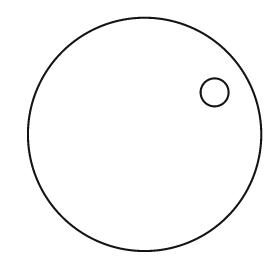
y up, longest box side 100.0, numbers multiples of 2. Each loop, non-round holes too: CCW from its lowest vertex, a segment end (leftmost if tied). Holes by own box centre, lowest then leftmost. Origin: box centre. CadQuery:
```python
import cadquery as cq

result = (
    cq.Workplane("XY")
    .moveTo(0.0, 0.0)
    .circle(50.0)
    .moveTo(30.0, 18.0)
    .circle(6.0)
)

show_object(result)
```